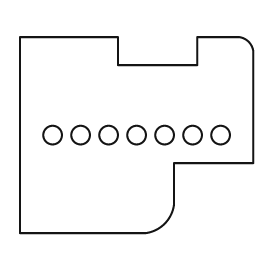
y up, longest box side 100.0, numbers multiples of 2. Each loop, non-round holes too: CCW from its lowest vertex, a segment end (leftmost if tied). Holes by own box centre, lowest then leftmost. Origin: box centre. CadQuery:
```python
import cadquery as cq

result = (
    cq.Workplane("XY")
    .moveTo(-50.0, -42.0)
    .lineTo(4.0, -42.0)
    .threePointArc((12.0, -38.0), (16.0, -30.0))
    .lineTo(16.0, -12.0)
    .lineTo(50.0, -12.0)
    .lineTo(50.0, 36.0)
    .threePointArc((48.0, 40.0), (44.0, 42.0))
    .lineTo(26.0, 42.0)
    .lineTo(26.0, 30.0)
    .lineTo(-8.0, 30.0)
    .lineTo(-8.0, 42.0)
    .lineTo(-50.0, 42.0)
    .close()
    .moveTo(-36.0, 0.0)
    .circle(4.0)
    .moveTo(-24.0, 0.0)
    .circle(4.0)
    .moveTo(-12.0, 0.0)
    .circle(4.0)
    .moveTo(0.0, 0.0)
    .circle(4.0)
    .moveTo(12.0, 0.0)
    .circle(4.0)
    .moveTo(24.0, 0.0)
    .circle(4.0)
    .moveTo(36.0, 0.0)
    .circle(4.0)
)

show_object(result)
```